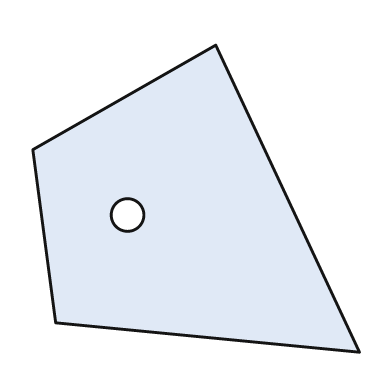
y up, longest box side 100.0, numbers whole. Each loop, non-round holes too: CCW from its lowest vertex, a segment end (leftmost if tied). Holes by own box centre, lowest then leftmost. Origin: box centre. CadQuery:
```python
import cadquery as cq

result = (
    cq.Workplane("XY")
    .moveTo(50.0, -47.0)
    .lineTo(6.0, 47.0)
    .lineTo(-50.0, 15.0)
    .lineTo(-43.0, -38.0)
    .close()
    .moveTo(-21.0, -5.0)
    .circle(5.0)
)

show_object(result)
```